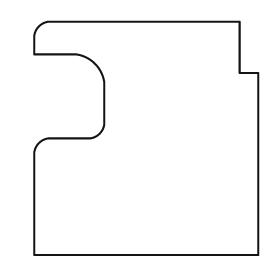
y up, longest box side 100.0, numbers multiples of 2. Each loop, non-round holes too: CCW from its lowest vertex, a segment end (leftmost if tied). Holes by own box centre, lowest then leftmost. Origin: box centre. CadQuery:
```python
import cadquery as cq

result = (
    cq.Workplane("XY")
    .moveTo(-48.0, -50.0)
    .lineTo(48.0, -50.0)
    .lineTo(48.0, 28.0)
    .lineTo(40.0, 28.0)
    .lineTo(40.0, 50.0)
    .lineTo(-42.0, 50.0)
    .threePointArc((-46.0, 48.0), (-48.0, 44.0))
    .lineTo(-48.0, 36.0)
    .lineTo(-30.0, 36.0)
    .threePointArc((-22.0, 32.0), (-18.0, 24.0))
    .lineTo(-18.0, 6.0)
    .threePointArc((-20.0, 2.0), (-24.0, 0.0))
    .lineTo(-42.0, 0.0)
    .threePointArc((-46.0, -2.0), (-48.0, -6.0))
    .close()
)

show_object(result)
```